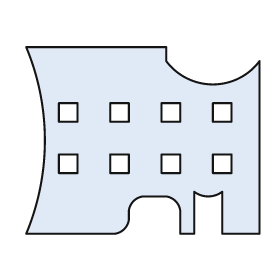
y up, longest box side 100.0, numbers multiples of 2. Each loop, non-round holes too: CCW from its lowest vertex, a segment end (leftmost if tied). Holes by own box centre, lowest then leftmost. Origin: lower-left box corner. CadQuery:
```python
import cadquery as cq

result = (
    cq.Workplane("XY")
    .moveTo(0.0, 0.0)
    .lineTo(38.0, 0.0)
    .threePointArc((42.0, 2.0), (44.0, 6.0))
    .lineTo(44.0, 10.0)
    .threePointArc((46.0, 14.0), (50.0, 16.0))
    .lineTo(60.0, 16.0)
    .threePointArc((64.0, 14.0), (66.0, 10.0))
    .lineTo(66.0, 0.0)
    .lineTo(72.0, 0.0)
    .lineTo(72.0, 18.0)
    .threePointArc((78.0, 16.0), (84.0, 18.0))
    .lineTo(84.0, 0.0)
    .lineTo(100.0, 0.0)
    .lineTo(100.0, 74.0)
    .threePointArc((80.0, 64.0), (60.0, 74.0))
    .lineTo(60.0, 80.0)
    .lineTo(0.0, 80.0)
    .threePointArc((8.0, 40.0), (0.0, 0.0))
    .close()
    .moveTo(14.0, 26.0)
    .lineTo(22.0, 26.0)
    .lineTo(22.0, 34.0)
    .lineTo(14.0, 34.0)
    .close()
    .moveTo(36.0, 26.0)
    .lineTo(44.0, 26.0)
    .lineTo(44.0, 34.0)
    .lineTo(36.0, 34.0)
    .close()
    .moveTo(58.0, 26.0)
    .lineTo(66.0, 26.0)
    .lineTo(66.0, 34.0)
    .lineTo(58.0, 34.0)
    .close()
    .moveTo(80.0, 26.0)
    .lineTo(88.0, 26.0)
    .lineTo(88.0, 34.0)
    .lineTo(80.0, 34.0)
    .close()
    .moveTo(14.0, 48.0)
    .lineTo(22.0, 48.0)
    .lineTo(22.0, 56.0)
    .lineTo(14.0, 56.0)
    .close()
    .moveTo(36.0, 48.0)
    .lineTo(44.0, 48.0)
    .lineTo(44.0, 56.0)
    .lineTo(36.0, 56.0)
    .close()
    .moveTo(58.0, 48.0)
    .lineTo(66.0, 48.0)
    .lineTo(66.0, 56.0)
    .lineTo(58.0, 56.0)
    .close()
    .moveTo(80.0, 48.0)
    .lineTo(88.0, 48.0)
    .lineTo(88.0, 56.0)
    .lineTo(80.0, 56.0)
    .close()
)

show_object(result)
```